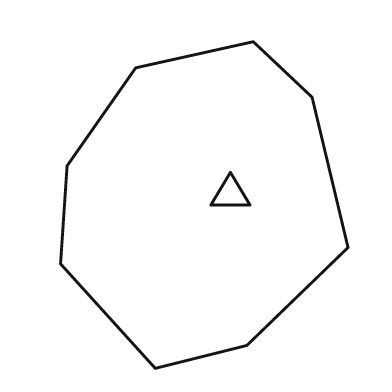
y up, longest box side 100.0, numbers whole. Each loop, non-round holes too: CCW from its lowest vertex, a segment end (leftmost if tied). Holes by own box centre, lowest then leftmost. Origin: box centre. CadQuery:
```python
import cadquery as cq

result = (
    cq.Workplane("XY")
    .moveTo(-15.0, -50.0)
    .lineTo(13.0, -43.0)
    .lineTo(44.0, -13.0)
    .lineTo(33.0, 33.0)
    .lineTo(15.0, 50.0)
    .lineTo(-21.0, 42.0)
    .lineTo(-42.0, 12.0)
    .lineTo(-44.0, -18.0)
    .close()
    .moveTo(2.0, 0.0)
    .lineTo(14.0, 0.0)
    .lineTo(8.0, 10.0)
    .close()
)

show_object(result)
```